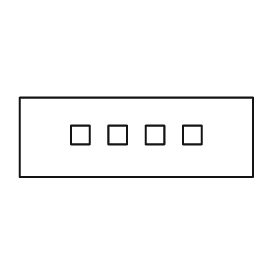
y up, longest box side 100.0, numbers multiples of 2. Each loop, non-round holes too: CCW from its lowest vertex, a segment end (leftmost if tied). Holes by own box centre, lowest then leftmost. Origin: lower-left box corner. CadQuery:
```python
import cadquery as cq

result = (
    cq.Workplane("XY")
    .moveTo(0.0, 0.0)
    .lineTo(100.0, 0.0)
    .lineTo(100.0, 34.0)
    .lineTo(0.0, 34.0)
    .close()
    .moveTo(22.0, 14.0)
    .lineTo(30.0, 14.0)
    .lineTo(30.0, 22.0)
    .lineTo(22.0, 22.0)
    .close()
    .moveTo(38.0, 14.0)
    .lineTo(46.0, 14.0)
    .lineTo(46.0, 22.0)
    .lineTo(38.0, 22.0)
    .close()
    .moveTo(54.0, 14.0)
    .lineTo(62.0, 14.0)
    .lineTo(62.0, 22.0)
    .lineTo(54.0, 22.0)
    .close()
    .moveTo(70.0, 14.0)
    .lineTo(78.0, 14.0)
    .lineTo(78.0, 22.0)
    .lineTo(70.0, 22.0)
    .close()
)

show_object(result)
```